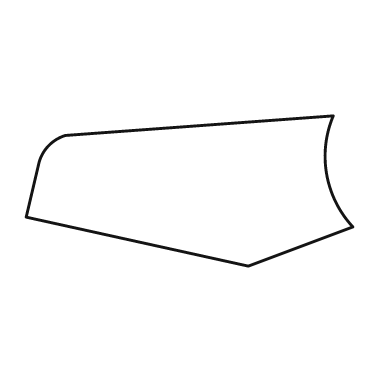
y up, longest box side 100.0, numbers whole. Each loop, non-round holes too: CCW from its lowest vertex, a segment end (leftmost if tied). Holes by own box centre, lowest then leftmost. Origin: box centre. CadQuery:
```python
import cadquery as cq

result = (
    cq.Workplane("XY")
    .moveTo(18.0, -23.0)
    .lineTo(50.0, -11.0)
    .threePointArc((42.0, 5.0), (44.0, 23.0))
    .lineTo(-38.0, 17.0)
    .threePointArc((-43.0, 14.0), (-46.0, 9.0))
    .lineTo(-50.0, -8.0)
    .close()
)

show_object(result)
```